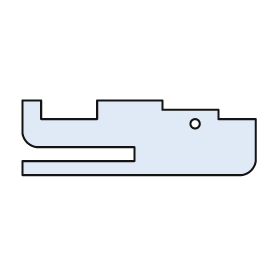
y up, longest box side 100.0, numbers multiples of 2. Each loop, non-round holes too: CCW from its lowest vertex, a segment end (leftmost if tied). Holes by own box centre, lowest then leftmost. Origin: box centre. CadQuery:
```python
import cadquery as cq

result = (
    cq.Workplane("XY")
    .moveTo(-50.0, -16.0)
    .lineTo(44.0, -16.0)
    .threePointArc((48.0, -14.0), (50.0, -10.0))
    .lineTo(50.0, 8.0)
    .lineTo(34.0, 8.0)
    .lineTo(34.0, 12.0)
    .lineTo(10.0, 12.0)
    .lineTo(10.0, 16.0)
    .lineTo(-18.0, 16.0)
    .lineTo(-18.0, 8.0)
    .lineTo(-42.0, 8.0)
    .lineTo(-42.0, 16.0)
    .lineTo(-50.0, 16.0)
    .lineTo(-50.0, 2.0)
    .threePointArc((-48.0, -2.0), (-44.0, -4.0))
    .lineTo(-2.0, -4.0)
    .lineTo(-2.0, -10.0)
    .lineTo(-50.0, -10.0)
    .close()
    .moveTo(24.0, 6.0)
    .circle(2.0)
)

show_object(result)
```